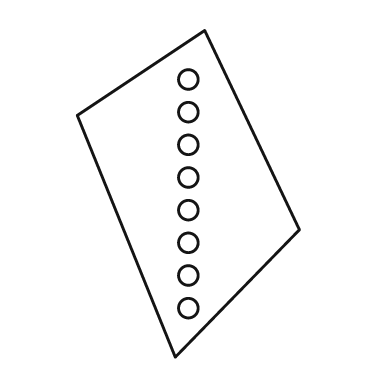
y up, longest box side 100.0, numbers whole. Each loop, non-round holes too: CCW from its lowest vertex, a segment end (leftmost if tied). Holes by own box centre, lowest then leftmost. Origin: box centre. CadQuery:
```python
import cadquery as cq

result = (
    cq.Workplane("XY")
    .moveTo(-4.0, -50.0)
    .lineTo(34.0, -11.0)
    .lineTo(5.0, 50.0)
    .lineTo(-34.0, 24.0)
    .close()
    .moveTo(0.0, -35.0)
    .circle(3.0)
    .moveTo(0.0, -25.0)
    .circle(3.0)
    .moveTo(0.0, -15.0)
    .circle(3.0)
    .moveTo(0.0, -5.0)
    .circle(3.0)
    .moveTo(0.0, 5.0)
    .circle(3.0)
    .moveTo(0.0, 15.0)
    .circle(3.0)
    .moveTo(0.0, 25.0)
    .circle(3.0)
    .moveTo(0.0, 35.0)
    .circle(3.0)
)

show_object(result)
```